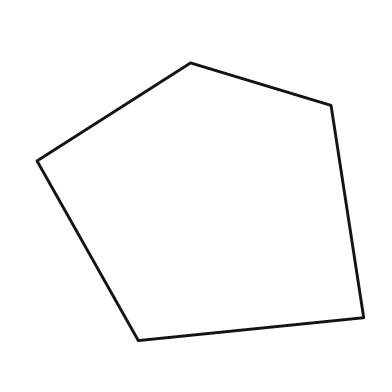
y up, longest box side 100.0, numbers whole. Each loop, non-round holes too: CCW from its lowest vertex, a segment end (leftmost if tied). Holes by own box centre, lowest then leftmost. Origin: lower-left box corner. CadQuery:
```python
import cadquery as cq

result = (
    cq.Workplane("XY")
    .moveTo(31.0, 0.0)
    .lineTo(100.0, 7.0)
    .lineTo(90.0, 72.0)
    .lineTo(47.0, 85.0)
    .lineTo(0.0, 55.0)
    .close()
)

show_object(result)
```